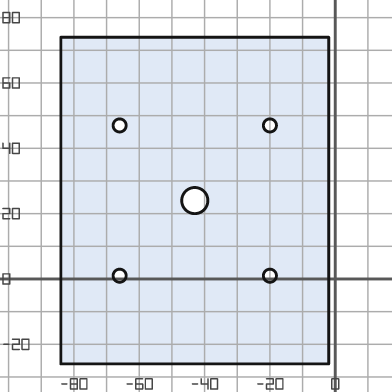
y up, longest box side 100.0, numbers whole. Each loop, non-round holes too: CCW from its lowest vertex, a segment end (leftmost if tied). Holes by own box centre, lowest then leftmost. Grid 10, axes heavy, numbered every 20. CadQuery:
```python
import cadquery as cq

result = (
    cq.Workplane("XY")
    .moveTo(-84.0, -26.0)
    .lineTo(-2.0, -26.0)
    .lineTo(-2.0, 74.0)
    .lineTo(-84.0, 74.0)
    .close()
    .moveTo(-66.0, 1.0)
    .circle(2.0)
    .moveTo(-20.0, 1.0)
    .circle(2.0)
    .moveTo(-43.0, 24.0)
    .circle(4.0)
    .moveTo(-66.0, 47.0)
    .circle(2.0)
    .moveTo(-20.0, 47.0)
    .circle(2.0)
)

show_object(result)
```